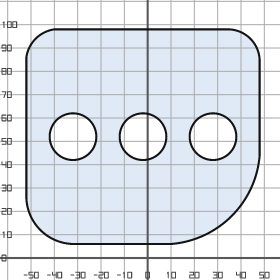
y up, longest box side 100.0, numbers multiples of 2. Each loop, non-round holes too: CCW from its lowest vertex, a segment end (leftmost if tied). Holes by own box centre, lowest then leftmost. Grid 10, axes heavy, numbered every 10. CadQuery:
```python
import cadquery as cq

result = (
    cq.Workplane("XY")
    .moveTo(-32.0, 6.0)
    .lineTo(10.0, 6.0)
    .threePointArc((36.0, 18.0), (48.0, 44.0))
    .lineTo(48.0, 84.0)
    .threePointArc((44.0, 94.0), (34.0, 98.0))
    .lineTo(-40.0, 98.0)
    .threePointArc((-48.0, 94.0), (-52.0, 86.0))
    .lineTo(-52.0, 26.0)
    .threePointArc((-46.0, 12.0), (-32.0, 6.0))
    .close()
    .moveTo(-32.0, 52.0)
    .circle(10.0)
    .moveTo(-2.0, 52.0)
    .circle(10.0)
    .moveTo(28.0, 52.0)
    .circle(10.0)
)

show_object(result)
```